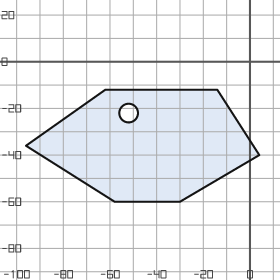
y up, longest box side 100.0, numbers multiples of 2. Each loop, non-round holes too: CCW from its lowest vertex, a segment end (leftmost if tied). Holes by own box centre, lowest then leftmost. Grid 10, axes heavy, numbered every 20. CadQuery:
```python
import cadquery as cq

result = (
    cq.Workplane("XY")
    .moveTo(-58.0, -60.0)
    .lineTo(-30.0, -60.0)
    .lineTo(4.0, -40.0)
    .lineTo(-14.0, -12.0)
    .lineTo(-62.0, -12.0)
    .lineTo(-96.0, -36.0)
    .close()
    .moveTo(-52.0, -22.0)
    .circle(4.0)
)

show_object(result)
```